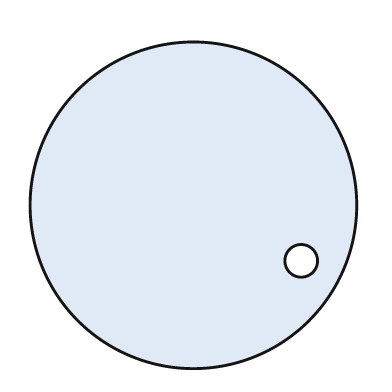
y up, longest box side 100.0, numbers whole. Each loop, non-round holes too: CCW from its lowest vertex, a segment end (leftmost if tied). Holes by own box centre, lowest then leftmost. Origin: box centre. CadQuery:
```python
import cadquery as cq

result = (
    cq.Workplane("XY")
    .moveTo(0.0, 0.0)
    .circle(50.0)
    .moveTo(33.0, -17.0)
    .circle(5.0)
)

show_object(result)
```